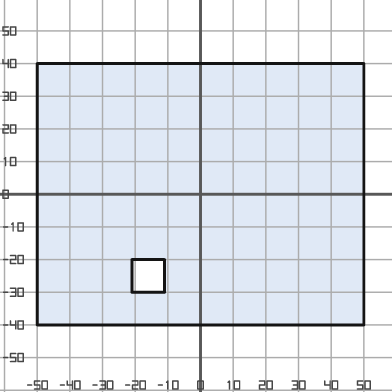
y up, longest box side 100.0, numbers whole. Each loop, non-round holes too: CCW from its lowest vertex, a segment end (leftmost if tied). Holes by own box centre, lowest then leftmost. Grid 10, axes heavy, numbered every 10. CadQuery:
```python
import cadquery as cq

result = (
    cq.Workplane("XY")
    .moveTo(-50.0, -40.0)
    .lineTo(50.0, -40.0)
    .lineTo(50.0, 40.0)
    .lineTo(-50.0, 40.0)
    .close()
    .moveTo(-21.0, -30.0)
    .lineTo(-11.0, -30.0)
    .lineTo(-11.0, -20.0)
    .lineTo(-21.0, -20.0)
    .close()
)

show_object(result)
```